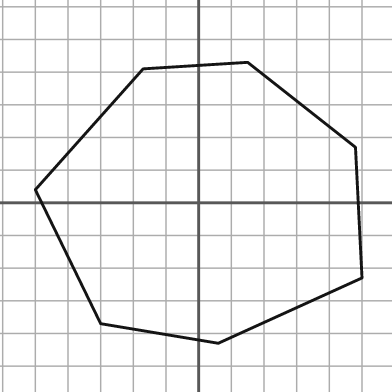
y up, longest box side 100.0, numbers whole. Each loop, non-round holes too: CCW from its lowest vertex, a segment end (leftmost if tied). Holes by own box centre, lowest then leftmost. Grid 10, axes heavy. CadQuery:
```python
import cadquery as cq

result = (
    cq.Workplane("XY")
    .moveTo(6.0, -43.0)
    .lineTo(50.0, -23.0)
    .lineTo(48.0, 17.0)
    .lineTo(15.0, 43.0)
    .lineTo(-17.0, 41.0)
    .lineTo(-50.0, 4.0)
    .lineTo(-30.0, -37.0)
    .close()
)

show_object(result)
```